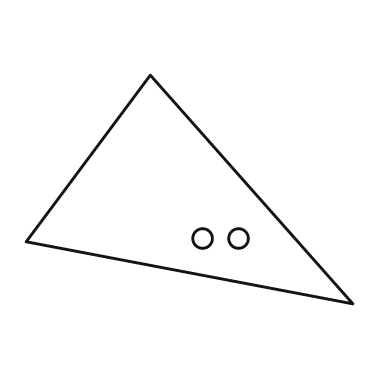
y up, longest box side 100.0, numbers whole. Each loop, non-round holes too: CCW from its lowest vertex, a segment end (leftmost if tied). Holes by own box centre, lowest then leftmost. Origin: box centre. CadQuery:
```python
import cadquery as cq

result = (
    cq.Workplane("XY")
    .moveTo(50.0, -35.0)
    .lineTo(-12.0, 35.0)
    .lineTo(-50.0, -16.0)
    .close()
    .moveTo(4.0, -15.0)
    .circle(3.0)
    .moveTo(15.0, -15.0)
    .circle(3.0)
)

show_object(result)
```